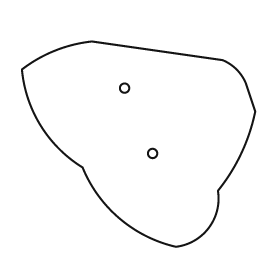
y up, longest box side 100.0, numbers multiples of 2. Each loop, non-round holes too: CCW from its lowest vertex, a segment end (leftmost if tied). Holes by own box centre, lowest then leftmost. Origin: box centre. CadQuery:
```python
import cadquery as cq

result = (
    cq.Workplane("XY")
    .moveTo(16.0, -44.0)
    .threePointArc((30.0, -36.0), (34.0, -20.0))
    .threePointArc((44.0, -4.0), (50.0, 14.0))
    .lineTo(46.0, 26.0)
    .threePointArc((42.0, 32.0), (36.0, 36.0))
    .lineTo(-20.0, 44.0)
    .threePointArc((-36.0, 40.0), (-50.0, 32.0))
    .threePointArc((-42.0, 8.0), (-24.0, -10.0))
    .threePointArc((-8.0, -32.0), (16.0, -44.0))
    .close()
    .moveTo(6.0, -4.0)
    .circle(2.0)
    .moveTo(-6.0, 24.0)
    .circle(2.0)
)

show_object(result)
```